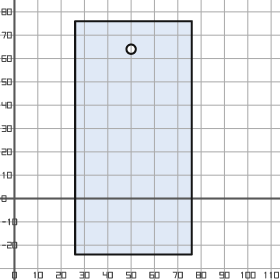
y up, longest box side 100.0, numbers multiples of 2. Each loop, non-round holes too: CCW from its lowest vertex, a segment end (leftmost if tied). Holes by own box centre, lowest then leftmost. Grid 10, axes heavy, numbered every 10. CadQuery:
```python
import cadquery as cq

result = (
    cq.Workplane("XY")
    .moveTo(26.0, -24.0)
    .lineTo(76.0, -24.0)
    .lineTo(76.0, 76.0)
    .lineTo(26.0, 76.0)
    .close()
    .moveTo(50.0, 64.0)
    .circle(2.0)
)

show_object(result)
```